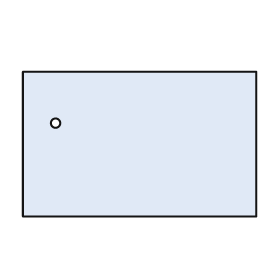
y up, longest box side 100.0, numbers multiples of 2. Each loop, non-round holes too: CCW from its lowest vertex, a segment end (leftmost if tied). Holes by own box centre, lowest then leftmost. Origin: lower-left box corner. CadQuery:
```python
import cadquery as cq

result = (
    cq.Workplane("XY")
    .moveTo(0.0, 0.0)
    .lineTo(100.0, 0.0)
    .lineTo(100.0, 62.0)
    .lineTo(0.0, 62.0)
    .close()
    .moveTo(14.0, 40.0)
    .circle(2.0)
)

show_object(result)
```